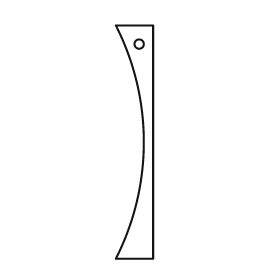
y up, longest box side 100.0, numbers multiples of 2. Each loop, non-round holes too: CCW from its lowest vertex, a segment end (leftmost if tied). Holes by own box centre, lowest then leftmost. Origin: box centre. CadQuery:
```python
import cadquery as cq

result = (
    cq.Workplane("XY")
    .moveTo(-8.0, -50.0)
    .lineTo(8.0, -50.0)
    .lineTo(8.0, 50.0)
    .lineTo(-8.0, 50.0)
    .threePointArc((4.0, 0.0), (-8.0, -50.0))
    .close()
    .moveTo(2.0, 42.0)
    .circle(2.0)
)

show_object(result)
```